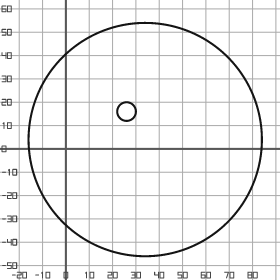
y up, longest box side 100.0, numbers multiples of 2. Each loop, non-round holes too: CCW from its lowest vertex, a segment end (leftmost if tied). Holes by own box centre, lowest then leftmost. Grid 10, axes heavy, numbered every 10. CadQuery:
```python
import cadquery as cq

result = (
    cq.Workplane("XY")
    .moveTo(34.0, 4.0)
    .circle(50.0)
    .moveTo(26.0, 16.0)
    .circle(4.0)
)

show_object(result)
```